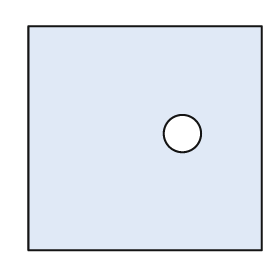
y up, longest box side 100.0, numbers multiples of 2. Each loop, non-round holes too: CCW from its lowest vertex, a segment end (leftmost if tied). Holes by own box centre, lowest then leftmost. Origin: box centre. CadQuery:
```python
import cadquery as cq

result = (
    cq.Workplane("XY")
    .moveTo(-50.0, -48.0)
    .lineTo(50.0, -48.0)
    .lineTo(50.0, 48.0)
    .lineTo(-50.0, 48.0)
    .close()
    .moveTo(16.0, 2.0)
    .circle(8.0)
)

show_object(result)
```